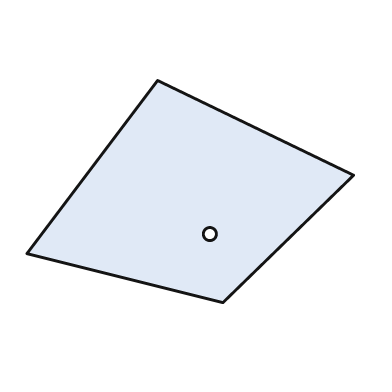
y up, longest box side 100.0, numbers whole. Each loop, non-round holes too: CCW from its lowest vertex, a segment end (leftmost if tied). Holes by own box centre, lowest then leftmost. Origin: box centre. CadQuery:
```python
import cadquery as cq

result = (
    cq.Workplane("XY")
    .moveTo(10.0, -34.0)
    .lineTo(50.0, 5.0)
    .lineTo(-10.0, 34.0)
    .lineTo(-50.0, -19.0)
    .close()
    .moveTo(6.0, -13.0)
    .circle(2.0)
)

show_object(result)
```